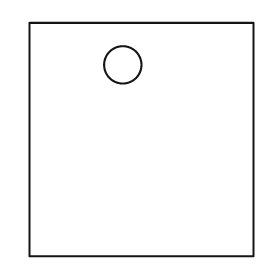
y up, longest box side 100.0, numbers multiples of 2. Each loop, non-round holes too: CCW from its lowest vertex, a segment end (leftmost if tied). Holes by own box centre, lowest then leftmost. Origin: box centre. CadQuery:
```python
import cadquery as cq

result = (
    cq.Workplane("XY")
    .moveTo(-48.0, -50.0)
    .lineTo(48.0, -50.0)
    .lineTo(48.0, 50.0)
    .lineTo(-48.0, 50.0)
    .close()
    .moveTo(-8.0, 32.0)
    .circle(8.0)
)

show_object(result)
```